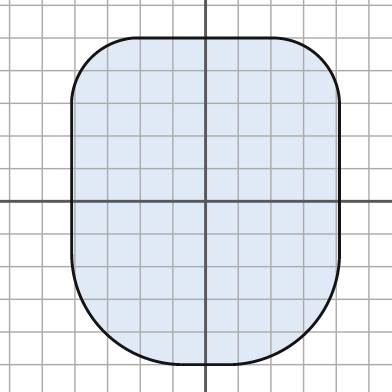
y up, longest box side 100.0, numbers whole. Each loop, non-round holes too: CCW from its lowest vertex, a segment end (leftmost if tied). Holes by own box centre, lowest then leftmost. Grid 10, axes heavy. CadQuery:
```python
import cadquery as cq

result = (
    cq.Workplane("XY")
    .moveTo(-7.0, -50.0)
    .lineTo(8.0, -50.0)
    .threePointArc((31.0, -40.0), (41.0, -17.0))
    .lineTo(41.0, 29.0)
    .threePointArc((35.0, 44.0), (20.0, 50.0))
    .lineTo(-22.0, 50.0)
    .threePointArc((-35.0, 44.0), (-41.0, 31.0))
    .lineTo(-41.0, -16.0)
    .threePointArc((-31.0, -40.0), (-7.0, -50.0))
    .close()
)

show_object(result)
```